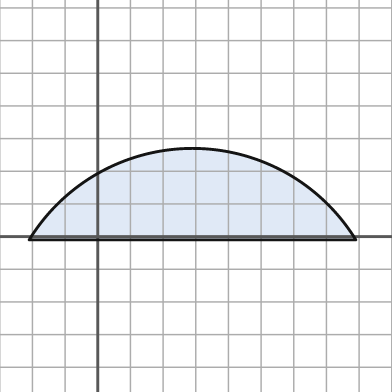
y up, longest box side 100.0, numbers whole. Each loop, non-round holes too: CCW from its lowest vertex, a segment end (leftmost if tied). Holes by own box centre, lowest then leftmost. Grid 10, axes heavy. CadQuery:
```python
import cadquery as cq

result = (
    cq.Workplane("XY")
    .moveTo(-21.0, -1.0)
    .lineTo(79.0, -1.0)
    .threePointArc((29.0, 27.0), (-21.0, -1.0))
    .close()
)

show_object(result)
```